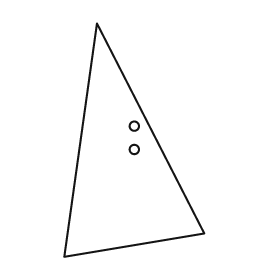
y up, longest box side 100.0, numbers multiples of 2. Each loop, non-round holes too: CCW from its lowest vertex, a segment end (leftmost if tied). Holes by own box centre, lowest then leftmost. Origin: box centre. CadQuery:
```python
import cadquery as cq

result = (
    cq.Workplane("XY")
    .moveTo(-30.0, -50.0)
    .lineTo(30.0, -40.0)
    .lineTo(-16.0, 50.0)
    .close()
    .moveTo(0.0, -4.0)
    .circle(2.0)
    .moveTo(0.0, 6.0)
    .circle(2.0)
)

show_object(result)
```